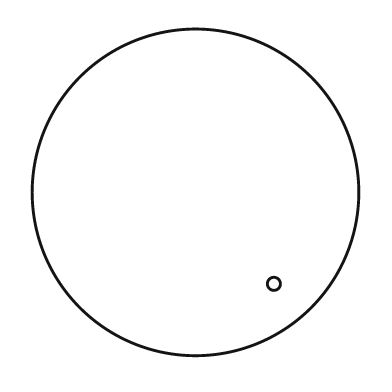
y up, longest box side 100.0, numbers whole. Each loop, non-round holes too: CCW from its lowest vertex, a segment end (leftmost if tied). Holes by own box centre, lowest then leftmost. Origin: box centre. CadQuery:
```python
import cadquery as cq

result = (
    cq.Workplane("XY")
    .moveTo(0.0, 0.0)
    .circle(50.0)
    .moveTo(24.0, -28.0)
    .circle(2.0)
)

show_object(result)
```